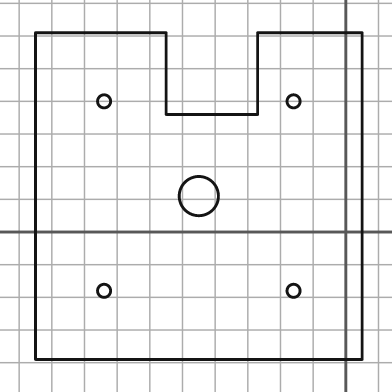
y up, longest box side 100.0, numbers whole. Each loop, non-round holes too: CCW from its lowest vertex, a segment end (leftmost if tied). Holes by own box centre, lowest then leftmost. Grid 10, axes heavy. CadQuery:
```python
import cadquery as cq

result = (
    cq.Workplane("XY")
    .moveTo(-95.0, -39.0)
    .lineTo(5.0, -39.0)
    .lineTo(5.0, 61.0)
    .lineTo(-27.0, 61.0)
    .lineTo(-27.0, 36.0)
    .lineTo(-55.0, 36.0)
    .lineTo(-55.0, 61.0)
    .lineTo(-95.0, 61.0)
    .close()
    .moveTo(-74.0, -18.0)
    .circle(2.0)
    .moveTo(-16.0, -18.0)
    .circle(2.0)
    .moveTo(-45.0, 11.0)
    .circle(6.0)
    .moveTo(-74.0, 40.0)
    .circle(2.0)
    .moveTo(-16.0, 40.0)
    .circle(2.0)
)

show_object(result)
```